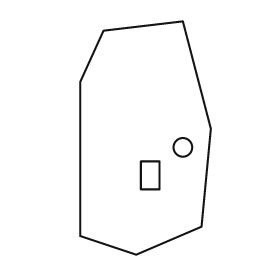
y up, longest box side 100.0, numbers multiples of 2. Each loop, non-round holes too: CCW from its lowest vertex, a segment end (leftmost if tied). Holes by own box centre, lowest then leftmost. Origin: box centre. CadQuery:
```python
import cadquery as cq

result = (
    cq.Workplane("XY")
    .moveTo(-4.0, -50.0)
    .lineTo(24.0, -38.0)
    .lineTo(28.0, 4.0)
    .lineTo(16.0, 50.0)
    .lineTo(-18.0, 46.0)
    .lineTo(-28.0, 24.0)
    .lineTo(-28.0, -42.0)
    .close()
    .moveTo(-2.0, -22.0)
    .lineTo(6.0, -22.0)
    .lineTo(6.0, -10.0)
    .lineTo(-2.0, -10.0)
    .close()
    .moveTo(16.0, -4.0)
    .circle(4.0)
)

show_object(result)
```